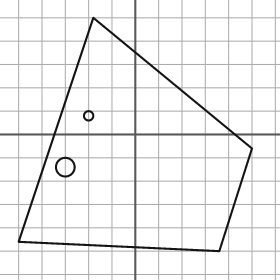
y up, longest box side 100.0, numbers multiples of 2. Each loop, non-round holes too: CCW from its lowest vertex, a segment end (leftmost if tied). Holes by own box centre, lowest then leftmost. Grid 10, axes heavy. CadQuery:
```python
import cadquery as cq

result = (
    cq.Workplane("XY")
    .moveTo(36.0, -50.0)
    .lineTo(50.0, -6.0)
    .lineTo(-18.0, 50.0)
    .lineTo(-50.0, -46.0)
    .close()
    .moveTo(-30.0, -14.0)
    .circle(4.0)
    .moveTo(-20.0, 8.0)
    .circle(2.0)
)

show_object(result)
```